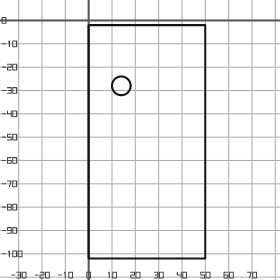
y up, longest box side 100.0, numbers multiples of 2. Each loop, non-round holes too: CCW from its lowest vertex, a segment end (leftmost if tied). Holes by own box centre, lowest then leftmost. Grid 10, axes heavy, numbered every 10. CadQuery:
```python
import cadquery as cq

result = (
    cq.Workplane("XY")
    .moveTo(0.0, -102.0)
    .lineTo(50.0, -102.0)
    .lineTo(50.0, -2.0)
    .lineTo(0.0, -2.0)
    .close()
    .moveTo(14.0, -28.0)
    .circle(4.0)
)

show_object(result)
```